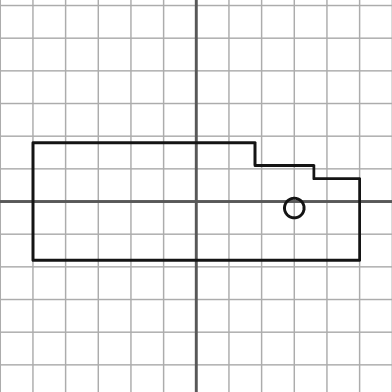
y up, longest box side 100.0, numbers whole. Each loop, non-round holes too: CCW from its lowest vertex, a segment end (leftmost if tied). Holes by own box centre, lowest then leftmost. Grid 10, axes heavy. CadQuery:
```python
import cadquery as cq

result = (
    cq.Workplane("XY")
    .moveTo(-50.0, -18.0)
    .lineTo(50.0, -18.0)
    .lineTo(50.0, 7.0)
    .lineTo(36.0, 7.0)
    .lineTo(36.0, 11.0)
    .lineTo(18.0, 11.0)
    .lineTo(18.0, 18.0)
    .lineTo(-50.0, 18.0)
    .close()
    .moveTo(30.0, -2.0)
    .circle(3.0)
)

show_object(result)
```